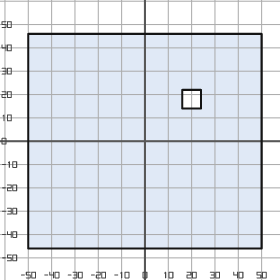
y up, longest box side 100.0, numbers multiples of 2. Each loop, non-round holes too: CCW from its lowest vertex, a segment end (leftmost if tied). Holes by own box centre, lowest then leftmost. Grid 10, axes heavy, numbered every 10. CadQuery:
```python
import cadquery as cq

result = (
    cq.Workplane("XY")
    .moveTo(-50.0, -46.0)
    .lineTo(50.0, -46.0)
    .lineTo(50.0, 46.0)
    .lineTo(-50.0, 46.0)
    .close()
    .moveTo(16.0, 14.0)
    .lineTo(24.0, 14.0)
    .lineTo(24.0, 22.0)
    .lineTo(16.0, 22.0)
    .close()
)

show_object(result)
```